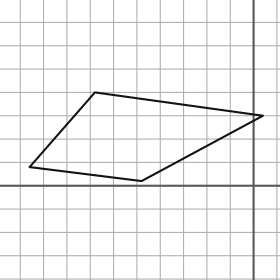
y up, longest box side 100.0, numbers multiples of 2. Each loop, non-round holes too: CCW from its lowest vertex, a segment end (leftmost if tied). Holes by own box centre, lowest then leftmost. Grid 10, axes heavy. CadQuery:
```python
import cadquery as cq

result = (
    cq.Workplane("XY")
    .moveTo(-48.0, 2.0)
    .lineTo(4.0, 30.0)
    .lineTo(-68.0, 40.0)
    .lineTo(-96.0, 8.0)
    .close()
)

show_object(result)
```